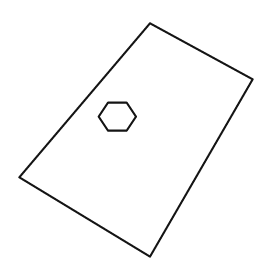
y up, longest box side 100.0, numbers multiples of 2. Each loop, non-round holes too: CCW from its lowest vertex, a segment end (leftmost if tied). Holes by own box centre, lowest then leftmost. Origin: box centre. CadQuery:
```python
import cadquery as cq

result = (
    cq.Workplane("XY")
    .moveTo(6.0, -50.0)
    .lineTo(50.0, 26.0)
    .lineTo(6.0, 50.0)
    .lineTo(-50.0, -16.0)
    .close()
    .moveTo(-12.0, 4.0)
    .lineTo(-4.0, 4.0)
    .lineTo(0.0, 10.0)
    .lineTo(-4.0, 16.0)
    .lineTo(-12.0, 16.0)
    .lineTo(-16.0, 10.0)
    .close()
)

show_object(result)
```